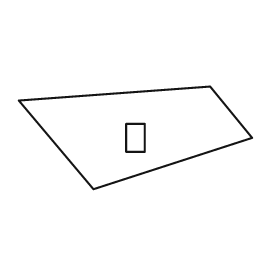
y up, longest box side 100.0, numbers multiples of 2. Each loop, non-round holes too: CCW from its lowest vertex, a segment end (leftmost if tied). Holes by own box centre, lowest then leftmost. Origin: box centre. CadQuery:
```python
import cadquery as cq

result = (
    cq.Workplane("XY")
    .moveTo(-18.0, -22.0)
    .lineTo(50.0, 0.0)
    .lineTo(32.0, 22.0)
    .lineTo(-50.0, 16.0)
    .close()
    .moveTo(-4.0, -6.0)
    .lineTo(4.0, -6.0)
    .lineTo(4.0, 6.0)
    .lineTo(-4.0, 6.0)
    .close()
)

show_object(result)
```